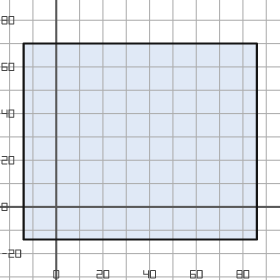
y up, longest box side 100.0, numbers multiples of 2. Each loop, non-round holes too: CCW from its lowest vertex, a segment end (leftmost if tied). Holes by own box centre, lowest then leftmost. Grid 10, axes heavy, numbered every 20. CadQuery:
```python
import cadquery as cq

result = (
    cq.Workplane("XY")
    .moveTo(-14.0, -14.0)
    .lineTo(86.0, -14.0)
    .lineTo(86.0, 70.0)
    .lineTo(-14.0, 70.0)
    .close()
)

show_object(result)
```